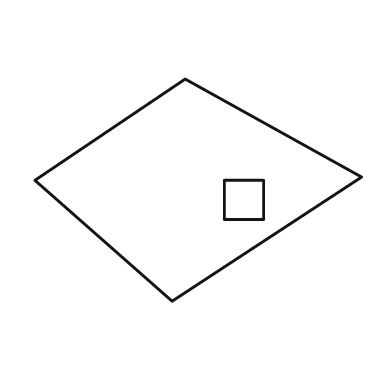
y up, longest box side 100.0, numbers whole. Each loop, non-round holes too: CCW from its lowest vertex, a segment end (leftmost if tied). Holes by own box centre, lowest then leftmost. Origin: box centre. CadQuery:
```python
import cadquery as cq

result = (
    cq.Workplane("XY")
    .moveTo(-8.0, -34.0)
    .lineTo(50.0, 4.0)
    .lineTo(-4.0, 34.0)
    .lineTo(-50.0, 3.0)
    .close()
    .moveTo(8.0, -9.0)
    .lineTo(20.0, -9.0)
    .lineTo(20.0, 3.0)
    .lineTo(8.0, 3.0)
    .close()
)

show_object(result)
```